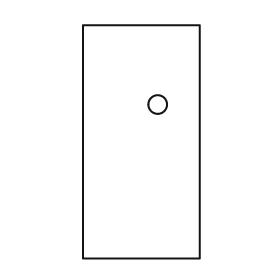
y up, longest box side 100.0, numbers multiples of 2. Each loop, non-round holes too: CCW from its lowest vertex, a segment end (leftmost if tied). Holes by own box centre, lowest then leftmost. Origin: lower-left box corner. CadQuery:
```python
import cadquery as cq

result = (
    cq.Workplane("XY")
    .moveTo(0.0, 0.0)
    .lineTo(50.0, 0.0)
    .lineTo(50.0, 100.0)
    .lineTo(0.0, 100.0)
    .close()
    .moveTo(32.0, 66.0)
    .circle(4.0)
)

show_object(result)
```